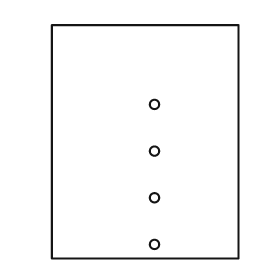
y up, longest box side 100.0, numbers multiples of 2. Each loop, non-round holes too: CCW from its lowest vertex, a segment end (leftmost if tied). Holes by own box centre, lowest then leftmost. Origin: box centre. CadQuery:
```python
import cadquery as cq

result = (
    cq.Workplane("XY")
    .moveTo(-40.0, -50.0)
    .lineTo(40.0, -50.0)
    .lineTo(40.0, 50.0)
    .lineTo(-40.0, 50.0)
    .close()
    .moveTo(4.0, -44.0)
    .circle(2.0)
    .moveTo(4.0, -24.0)
    .circle(2.0)
    .moveTo(4.0, -4.0)
    .circle(2.0)
    .moveTo(4.0, 16.0)
    .circle(2.0)
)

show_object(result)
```